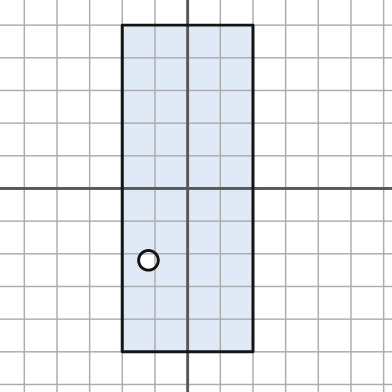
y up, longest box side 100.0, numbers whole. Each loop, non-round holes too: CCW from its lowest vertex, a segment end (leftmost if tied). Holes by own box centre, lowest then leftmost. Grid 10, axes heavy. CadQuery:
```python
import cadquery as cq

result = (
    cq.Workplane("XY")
    .moveTo(-20.0, -50.0)
    .lineTo(20.0, -50.0)
    .lineTo(20.0, 50.0)
    .lineTo(-20.0, 50.0)
    .close()
    .moveTo(-12.0, -22.0)
    .circle(3.0)
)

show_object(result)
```